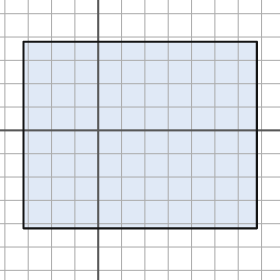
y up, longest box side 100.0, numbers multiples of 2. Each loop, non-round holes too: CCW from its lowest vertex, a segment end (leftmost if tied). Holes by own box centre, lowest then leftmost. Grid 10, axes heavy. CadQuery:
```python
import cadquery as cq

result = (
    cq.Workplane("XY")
    .moveTo(-32.0, -42.0)
    .lineTo(68.0, -42.0)
    .lineTo(68.0, 38.0)
    .lineTo(-32.0, 38.0)
    .close()
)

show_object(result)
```